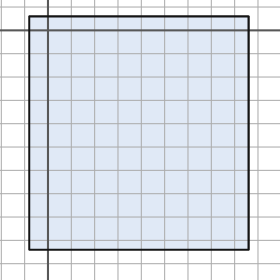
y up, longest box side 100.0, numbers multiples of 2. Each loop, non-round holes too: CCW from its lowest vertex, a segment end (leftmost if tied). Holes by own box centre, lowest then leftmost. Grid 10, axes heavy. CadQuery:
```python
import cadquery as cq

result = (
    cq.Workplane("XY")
    .moveTo(-8.0, -94.0)
    .lineTo(86.0, -94.0)
    .lineTo(86.0, 6.0)
    .lineTo(-8.0, 6.0)
    .close()
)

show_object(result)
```